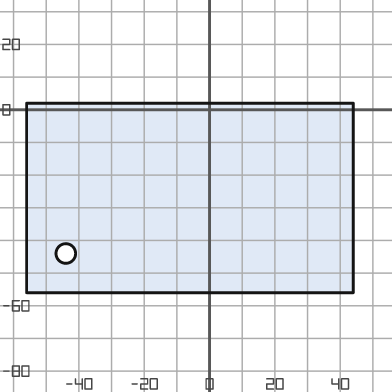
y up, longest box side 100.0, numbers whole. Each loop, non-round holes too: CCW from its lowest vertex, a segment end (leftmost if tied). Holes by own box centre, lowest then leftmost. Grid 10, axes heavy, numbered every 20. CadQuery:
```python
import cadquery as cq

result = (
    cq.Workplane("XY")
    .moveTo(-56.0, -56.0)
    .lineTo(44.0, -56.0)
    .lineTo(44.0, 2.0)
    .lineTo(-56.0, 2.0)
    .close()
    .moveTo(-44.0, -44.0)
    .circle(3.0)
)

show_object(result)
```